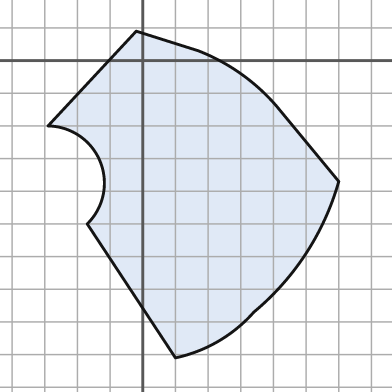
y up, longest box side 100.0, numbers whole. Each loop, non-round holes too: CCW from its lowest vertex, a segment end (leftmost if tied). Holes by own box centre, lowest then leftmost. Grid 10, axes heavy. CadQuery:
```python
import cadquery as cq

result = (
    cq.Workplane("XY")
    .moveTo(10.0, -91.0)
    .threePointArc((23.0, -86.0), (34.0, -77.0))
    .threePointArc((50.0, -59.0), (60.0, -37.0))
    .lineTo(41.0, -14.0)
    .threePointArc((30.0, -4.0), (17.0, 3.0))
    .lineTo(-2.0, 9.0)
    .lineTo(-29.0, -20.0)
    .threePointArc((-13.0, -31.0), (-17.0, -50.0))
    .close()
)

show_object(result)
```